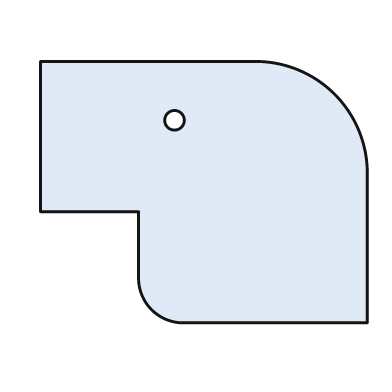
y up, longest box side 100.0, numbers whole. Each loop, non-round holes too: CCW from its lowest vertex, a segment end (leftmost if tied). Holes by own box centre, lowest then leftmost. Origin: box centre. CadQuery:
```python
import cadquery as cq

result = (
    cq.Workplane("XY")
    .moveTo(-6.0, -40.0)
    .lineTo(50.0, -40.0)
    .lineTo(50.0, 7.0)
    .threePointArc((40.0, 30.0), (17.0, 40.0))
    .lineTo(-50.0, 40.0)
    .lineTo(-50.0, -6.0)
    .lineTo(-20.0, -6.0)
    .lineTo(-20.0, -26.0)
    .threePointArc((-16.0, -36.0), (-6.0, -40.0))
    .close()
    .moveTo(-9.0, 22.0)
    .circle(3.0)
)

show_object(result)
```